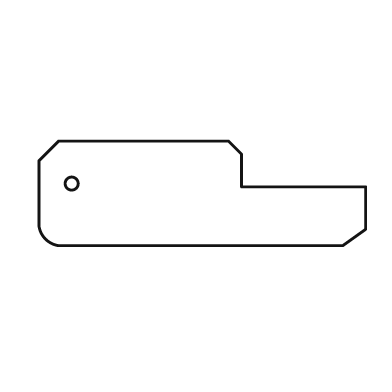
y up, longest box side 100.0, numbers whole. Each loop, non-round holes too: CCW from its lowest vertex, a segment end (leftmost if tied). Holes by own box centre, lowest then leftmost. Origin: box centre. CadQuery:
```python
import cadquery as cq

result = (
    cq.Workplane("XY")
    .moveTo(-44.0, -16.0)
    .lineTo(43.0, -16.0)
    .lineTo(50.0, -11.0)
    .lineTo(50.0, 2.0)
    .lineTo(12.0, 2.0)
    .lineTo(12.0, 12.0)
    .lineTo(8.0, 16.0)
    .lineTo(-44.0, 16.0)
    .lineTo(-50.0, 10.0)
    .lineTo(-50.0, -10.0)
    .threePointArc((-48.0, -14.0), (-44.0, -16.0))
    .close()
    .moveTo(-40.0, 3.0)
    .circle(2.0)
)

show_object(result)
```